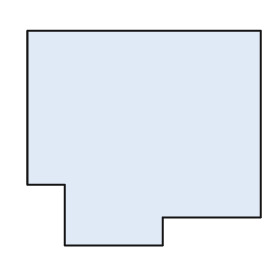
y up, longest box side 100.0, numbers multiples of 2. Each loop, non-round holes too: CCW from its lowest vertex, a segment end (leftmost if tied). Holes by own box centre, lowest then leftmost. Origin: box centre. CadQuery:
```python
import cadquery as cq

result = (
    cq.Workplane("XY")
    .moveTo(-34.0, -46.0)
    .lineTo(8.0, -46.0)
    .lineTo(8.0, -34.0)
    .lineTo(50.0, -34.0)
    .lineTo(50.0, 46.0)
    .lineTo(-50.0, 46.0)
    .lineTo(-50.0, -20.0)
    .lineTo(-34.0, -20.0)
    .close()
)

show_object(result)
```